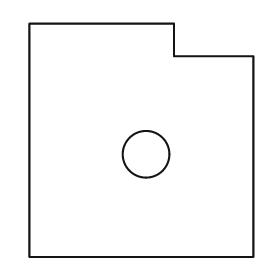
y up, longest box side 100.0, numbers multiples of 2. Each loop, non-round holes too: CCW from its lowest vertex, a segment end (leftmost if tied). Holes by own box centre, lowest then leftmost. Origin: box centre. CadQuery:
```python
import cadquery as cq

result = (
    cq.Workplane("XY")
    .moveTo(-48.0, -50.0)
    .lineTo(48.0, -50.0)
    .lineTo(48.0, 36.0)
    .lineTo(14.0, 36.0)
    .lineTo(14.0, 50.0)
    .lineTo(-48.0, 50.0)
    .close()
    .moveTo(2.0, -6.0)
    .circle(10.0)
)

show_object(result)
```